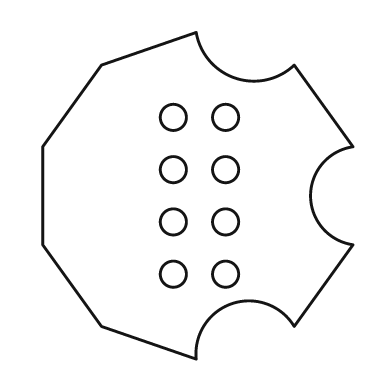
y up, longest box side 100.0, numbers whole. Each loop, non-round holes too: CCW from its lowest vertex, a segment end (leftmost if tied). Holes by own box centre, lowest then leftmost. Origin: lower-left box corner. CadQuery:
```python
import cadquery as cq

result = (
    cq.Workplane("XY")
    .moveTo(47.0, 0.0)
    .threePointArc((58.0, 17.0), (77.0, 10.0))
    .lineTo(95.0, 35.0)
    .threePointArc((82.0, 50.0), (95.0, 65.0))
    .lineTo(77.0, 90.0)
    .threePointArc((59.0, 86.0), (47.0, 100.0))
    .lineTo(18.0, 90.0)
    .lineTo(0.0, 65.0)
    .lineTo(0.0, 35.0)
    .lineTo(18.0, 10.0)
    .close()
    .moveTo(40.0, 26.0)
    .circle(4.0)
    .moveTo(56.0, 26.0)
    .circle(4.0)
    .moveTo(40.0, 42.0)
    .circle(4.0)
    .moveTo(56.0, 42.0)
    .circle(4.0)
    .moveTo(40.0, 58.0)
    .circle(4.0)
    .moveTo(56.0, 58.0)
    .circle(4.0)
    .moveTo(40.0, 74.0)
    .circle(4.0)
    .moveTo(56.0, 74.0)
    .circle(4.0)
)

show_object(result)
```